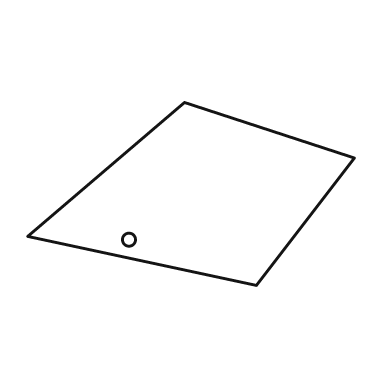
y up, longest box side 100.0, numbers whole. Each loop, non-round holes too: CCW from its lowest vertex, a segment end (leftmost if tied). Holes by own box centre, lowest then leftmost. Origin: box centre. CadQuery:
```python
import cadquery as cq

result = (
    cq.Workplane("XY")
    .moveTo(20.0, -28.0)
    .lineTo(50.0, 11.0)
    .lineTo(-2.0, 28.0)
    .lineTo(-50.0, -13.0)
    .close()
    .moveTo(-19.0, -14.0)
    .circle(2.0)
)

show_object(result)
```